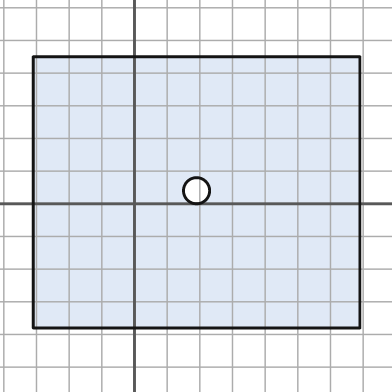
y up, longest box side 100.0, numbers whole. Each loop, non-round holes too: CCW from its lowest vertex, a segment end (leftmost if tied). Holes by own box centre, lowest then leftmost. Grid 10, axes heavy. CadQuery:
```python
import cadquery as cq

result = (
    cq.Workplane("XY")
    .moveTo(-31.0, -38.0)
    .lineTo(69.0, -38.0)
    .lineTo(69.0, 45.0)
    .lineTo(-31.0, 45.0)
    .close()
    .moveTo(19.0, 4.0)
    .circle(4.0)
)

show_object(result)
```